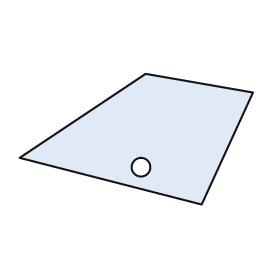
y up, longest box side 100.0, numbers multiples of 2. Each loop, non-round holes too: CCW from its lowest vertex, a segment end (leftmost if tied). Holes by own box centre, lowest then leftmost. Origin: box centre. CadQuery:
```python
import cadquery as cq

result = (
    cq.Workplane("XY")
    .moveTo(28.0, -28.0)
    .lineTo(50.0, 20.0)
    .lineTo(4.0, 28.0)
    .lineTo(-50.0, -8.0)
    .close()
    .moveTo(2.0, -12.0)
    .circle(4.0)
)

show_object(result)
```